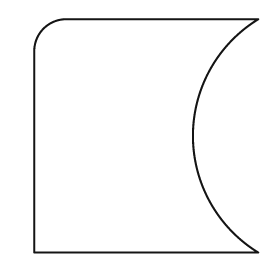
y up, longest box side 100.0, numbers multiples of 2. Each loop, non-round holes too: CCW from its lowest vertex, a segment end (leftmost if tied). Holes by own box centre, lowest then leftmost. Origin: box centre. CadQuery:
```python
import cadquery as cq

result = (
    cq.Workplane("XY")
    .moveTo(-48.0, -50.0)
    .lineTo(48.0, -50.0)
    .threePointArc((20.0, 0.0), (48.0, 50.0))
    .lineTo(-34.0, 50.0)
    .threePointArc((-44.0, 46.0), (-48.0, 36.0))
    .close()
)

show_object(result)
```